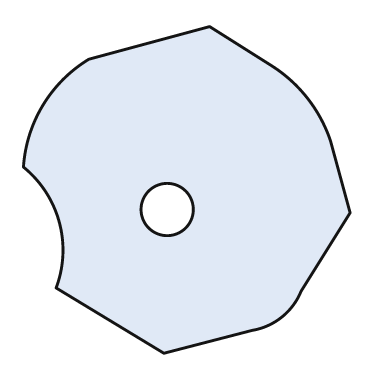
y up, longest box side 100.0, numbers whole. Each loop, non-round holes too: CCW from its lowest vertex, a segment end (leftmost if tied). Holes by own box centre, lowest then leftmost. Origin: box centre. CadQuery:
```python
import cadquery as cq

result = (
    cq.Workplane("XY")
    .moveTo(-7.0, -50.0)
    .lineTo(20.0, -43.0)
    .threePointArc((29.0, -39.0), (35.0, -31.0))
    .lineTo(50.0, -7.0)
    .lineTo(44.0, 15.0)
    .threePointArc((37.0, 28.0), (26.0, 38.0))
    .lineTo(7.0, 50.0)
    .lineTo(-30.0, 40.0)
    .threePointArc((-44.0, 26.0), (-50.0, 7.0))
    .threePointArc((-39.0, -10.0), (-40.0, -30.0))
    .close()
    .moveTo(-6.0, -6.0)
    .circle(8.0)
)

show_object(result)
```